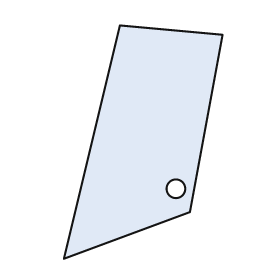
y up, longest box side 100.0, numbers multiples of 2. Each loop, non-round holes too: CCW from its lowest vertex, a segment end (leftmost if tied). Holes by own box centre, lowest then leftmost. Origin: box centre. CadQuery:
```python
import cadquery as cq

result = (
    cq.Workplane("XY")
    .moveTo(-34.0, -50.0)
    .lineTo(20.0, -30.0)
    .lineTo(34.0, 46.0)
    .lineTo(-10.0, 50.0)
    .close()
    .moveTo(14.0, -20.0)
    .circle(4.0)
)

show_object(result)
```